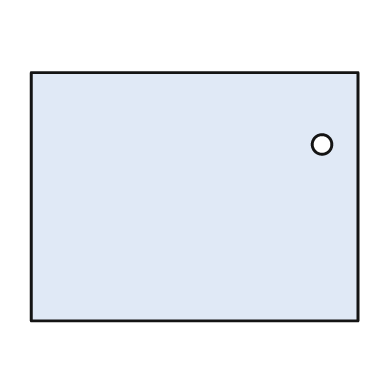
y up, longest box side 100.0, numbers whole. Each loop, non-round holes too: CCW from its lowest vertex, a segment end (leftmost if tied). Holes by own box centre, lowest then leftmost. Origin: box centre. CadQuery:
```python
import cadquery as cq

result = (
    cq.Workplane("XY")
    .moveTo(-50.0, -38.0)
    .lineTo(50.0, -38.0)
    .lineTo(50.0, 38.0)
    .lineTo(-50.0, 38.0)
    .close()
    .moveTo(39.0, 16.0)
    .circle(3.0)
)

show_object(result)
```